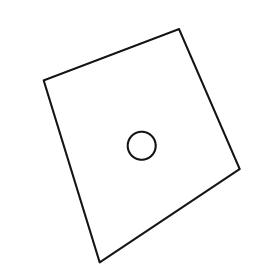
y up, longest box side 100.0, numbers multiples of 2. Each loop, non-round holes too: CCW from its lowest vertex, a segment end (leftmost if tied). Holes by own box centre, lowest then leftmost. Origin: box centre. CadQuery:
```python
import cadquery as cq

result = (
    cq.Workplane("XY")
    .moveTo(-18.0, -50.0)
    .lineTo(42.0, -10.0)
    .lineTo(16.0, 50.0)
    .lineTo(-42.0, 28.0)
    .close()
    .moveTo(0.0, 0.0)
    .circle(6.0)
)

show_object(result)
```